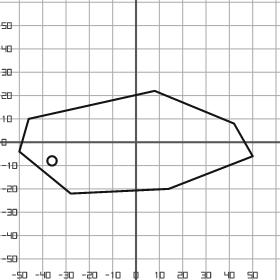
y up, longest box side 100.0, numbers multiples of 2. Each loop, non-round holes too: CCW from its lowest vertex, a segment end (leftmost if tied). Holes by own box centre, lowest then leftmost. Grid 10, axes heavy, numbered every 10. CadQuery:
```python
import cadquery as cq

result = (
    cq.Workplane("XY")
    .moveTo(-28.0, -22.0)
    .lineTo(14.0, -20.0)
    .lineTo(50.0, -6.0)
    .lineTo(42.0, 8.0)
    .lineTo(8.0, 22.0)
    .lineTo(-46.0, 10.0)
    .lineTo(-50.0, -4.0)
    .close()
    .moveTo(-36.0, -8.0)
    .circle(2.0)
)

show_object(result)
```